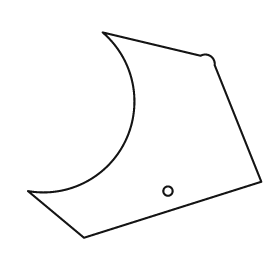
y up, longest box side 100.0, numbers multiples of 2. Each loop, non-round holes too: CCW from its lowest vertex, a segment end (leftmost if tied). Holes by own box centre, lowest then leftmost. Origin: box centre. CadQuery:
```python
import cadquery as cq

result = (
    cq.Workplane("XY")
    .moveTo(-26.0, -44.0)
    .lineTo(50.0, -20.0)
    .lineTo(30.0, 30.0)
    .threePointArc((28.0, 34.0), (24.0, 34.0))
    .lineTo(-18.0, 44.0)
    .threePointArc((-8.0, -2.0), (-50.0, -24.0))
    .close()
    .moveTo(10.0, -24.0)
    .circle(2.0)
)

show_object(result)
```